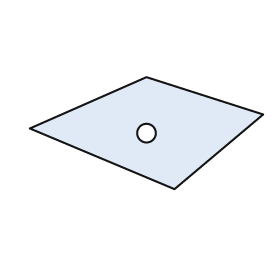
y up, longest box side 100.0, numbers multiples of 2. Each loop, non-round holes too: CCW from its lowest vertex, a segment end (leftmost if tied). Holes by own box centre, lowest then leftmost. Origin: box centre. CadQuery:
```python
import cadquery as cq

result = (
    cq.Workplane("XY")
    .moveTo(12.0, -24.0)
    .lineTo(50.0, 8.0)
    .lineTo(0.0, 24.0)
    .lineTo(-50.0, 2.0)
    .close()
    .moveTo(0.0, 0.0)
    .circle(4.0)
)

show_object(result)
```